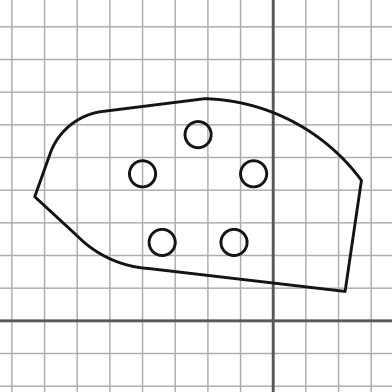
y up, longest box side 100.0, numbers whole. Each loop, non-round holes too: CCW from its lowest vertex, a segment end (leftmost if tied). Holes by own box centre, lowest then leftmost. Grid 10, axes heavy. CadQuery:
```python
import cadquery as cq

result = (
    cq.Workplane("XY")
    .moveTo(22.0, 9.0)
    .lineTo(27.0, 43.0)
    .threePointArc((6.0, 61.0), (-21.0, 68.0))
    .lineTo(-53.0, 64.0)
    .threePointArc((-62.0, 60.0), (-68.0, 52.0))
    .lineTo(-73.0, 38.0)
    .lineTo(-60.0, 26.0)
    .threePointArc((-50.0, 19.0), (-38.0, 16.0))
    .close()
    .moveTo(-34.0, 24.0)
    .circle(4.0)
    .moveTo(-12.0, 24.0)
    .circle(4.0)
    .moveTo(-40.0, 45.0)
    .circle(4.0)
    .moveTo(-6.0, 45.0)
    .circle(4.0)
    .moveTo(-23.0, 57.0)
    .circle(4.0)
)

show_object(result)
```